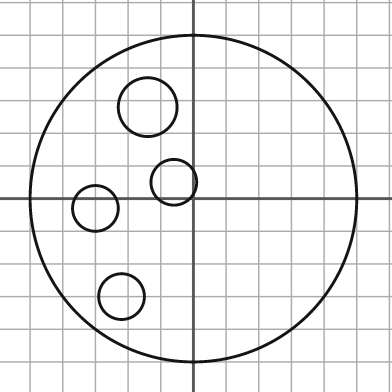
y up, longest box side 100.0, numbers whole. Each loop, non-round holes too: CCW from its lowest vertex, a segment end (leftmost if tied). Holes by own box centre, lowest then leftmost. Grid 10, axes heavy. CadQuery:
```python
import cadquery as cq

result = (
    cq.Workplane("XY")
    .moveTo(0.0, 0.0)
    .circle(50.0)
    .moveTo(-22.0, -30.0)
    .circle(7.0)
    .moveTo(-30.0, -3.0)
    .circle(7.0)
    .moveTo(-6.0, 5.0)
    .circle(7.0)
    .moveTo(-14.0, 28.0)
    .circle(9.0)
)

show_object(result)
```